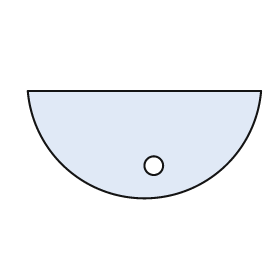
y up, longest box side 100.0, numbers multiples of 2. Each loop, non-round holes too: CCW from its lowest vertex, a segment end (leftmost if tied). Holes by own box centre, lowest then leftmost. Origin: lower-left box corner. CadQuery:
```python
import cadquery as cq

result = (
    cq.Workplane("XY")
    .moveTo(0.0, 46.0)
    .threePointArc((50.0, 0.0), (100.0, 46.0))
    .close()
    .moveTo(54.0, 14.0)
    .circle(4.0)
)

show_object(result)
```